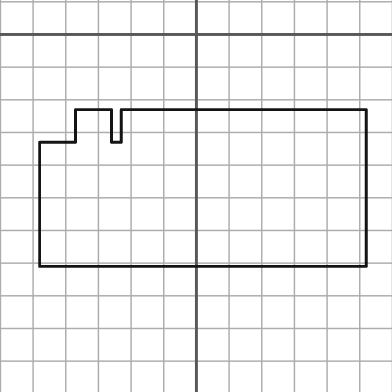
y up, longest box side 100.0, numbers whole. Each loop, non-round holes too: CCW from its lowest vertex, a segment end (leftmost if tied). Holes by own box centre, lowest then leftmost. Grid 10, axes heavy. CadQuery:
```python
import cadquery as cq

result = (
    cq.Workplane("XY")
    .moveTo(-48.0, -71.0)
    .lineTo(52.0, -71.0)
    .lineTo(52.0, -23.0)
    .lineTo(-23.0, -23.0)
    .lineTo(-23.0, -33.0)
    .lineTo(-26.0, -33.0)
    .lineTo(-26.0, -23.0)
    .lineTo(-37.0, -23.0)
    .lineTo(-37.0, -33.0)
    .lineTo(-48.0, -33.0)
    .close()
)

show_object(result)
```